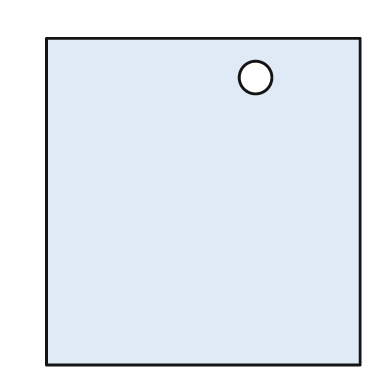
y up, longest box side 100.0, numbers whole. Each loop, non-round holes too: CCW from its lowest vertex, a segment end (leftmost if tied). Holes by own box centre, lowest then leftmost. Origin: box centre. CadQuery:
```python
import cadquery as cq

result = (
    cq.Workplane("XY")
    .moveTo(-48.0, -50.0)
    .lineTo(48.0, -50.0)
    .lineTo(48.0, 50.0)
    .lineTo(-48.0, 50.0)
    .close()
    .moveTo(16.0, 38.0)
    .circle(5.0)
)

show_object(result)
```